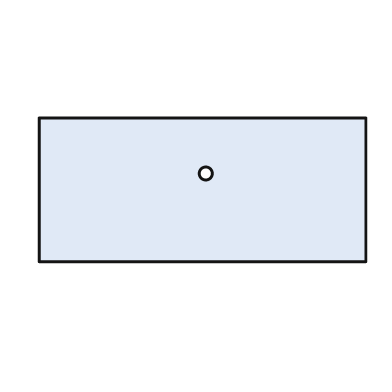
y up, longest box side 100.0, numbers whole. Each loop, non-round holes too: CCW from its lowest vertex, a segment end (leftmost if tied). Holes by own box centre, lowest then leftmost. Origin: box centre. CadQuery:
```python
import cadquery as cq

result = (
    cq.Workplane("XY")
    .moveTo(-50.0, -22.0)
    .lineTo(50.0, -22.0)
    .lineTo(50.0, 22.0)
    .lineTo(-50.0, 22.0)
    .close()
    .moveTo(1.0, 5.0)
    .circle(2.0)
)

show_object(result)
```